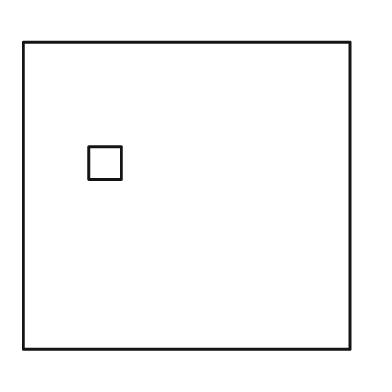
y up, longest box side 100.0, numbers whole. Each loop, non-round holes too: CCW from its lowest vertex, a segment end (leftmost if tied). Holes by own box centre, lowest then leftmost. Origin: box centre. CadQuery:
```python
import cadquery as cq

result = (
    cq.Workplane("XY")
    .moveTo(-50.0, -47.0)
    .lineTo(50.0, -47.0)
    .lineTo(50.0, 47.0)
    .lineTo(-50.0, 47.0)
    .close()
    .moveTo(-30.0, 5.0)
    .lineTo(-20.0, 5.0)
    .lineTo(-20.0, 15.0)
    .lineTo(-30.0, 15.0)
    .close()
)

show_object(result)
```